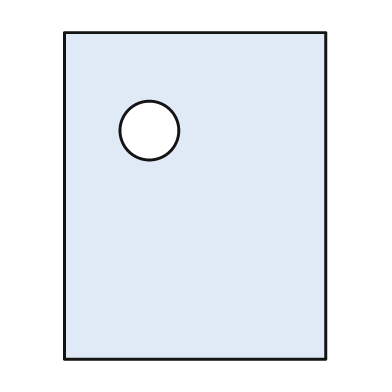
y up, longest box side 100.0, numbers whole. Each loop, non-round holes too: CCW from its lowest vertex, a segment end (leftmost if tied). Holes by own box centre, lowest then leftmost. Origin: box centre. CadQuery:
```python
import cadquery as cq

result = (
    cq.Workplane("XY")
    .moveTo(-40.0, -50.0)
    .lineTo(40.0, -50.0)
    .lineTo(40.0, 50.0)
    .lineTo(-40.0, 50.0)
    .close()
    .moveTo(-14.0, 20.0)
    .circle(9.0)
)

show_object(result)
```